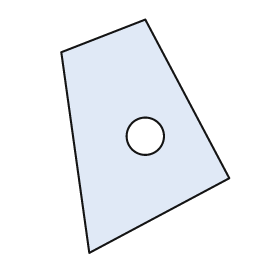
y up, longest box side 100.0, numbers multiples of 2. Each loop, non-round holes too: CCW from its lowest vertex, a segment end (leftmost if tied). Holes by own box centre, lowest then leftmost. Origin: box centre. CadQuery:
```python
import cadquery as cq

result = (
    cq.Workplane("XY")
    .moveTo(-24.0, -50.0)
    .lineTo(36.0, -18.0)
    .lineTo(0.0, 50.0)
    .lineTo(-36.0, 36.0)
    .close()
    .moveTo(0.0, 0.0)
    .circle(8.0)
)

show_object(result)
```